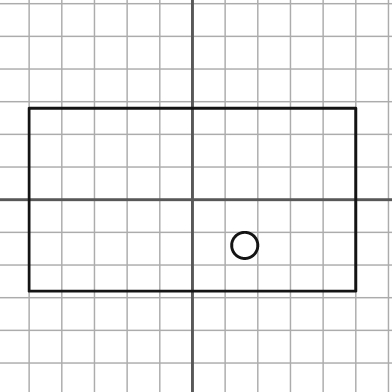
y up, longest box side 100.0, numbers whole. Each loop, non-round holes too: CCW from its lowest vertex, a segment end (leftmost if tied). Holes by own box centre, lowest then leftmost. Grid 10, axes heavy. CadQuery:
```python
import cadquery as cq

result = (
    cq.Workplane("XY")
    .moveTo(-50.0, -28.0)
    .lineTo(50.0, -28.0)
    .lineTo(50.0, 28.0)
    .lineTo(-50.0, 28.0)
    .close()
    .moveTo(16.0, -14.0)
    .circle(4.0)
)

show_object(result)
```